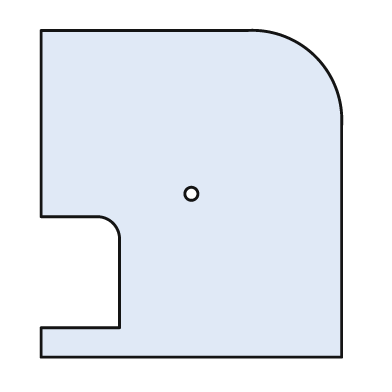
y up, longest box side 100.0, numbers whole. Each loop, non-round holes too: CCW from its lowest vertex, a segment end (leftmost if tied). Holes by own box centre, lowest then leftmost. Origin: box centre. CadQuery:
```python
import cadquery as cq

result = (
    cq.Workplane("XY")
    .moveTo(-46.0, -50.0)
    .lineTo(46.0, -50.0)
    .lineTo(46.0, 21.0)
    .threePointArc((38.0, 42.0), (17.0, 50.0))
    .lineTo(-46.0, 50.0)
    .lineTo(-46.0, -7.0)
    .lineTo(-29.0, -7.0)
    .threePointArc((-24.0, -9.0), (-22.0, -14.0))
    .lineTo(-22.0, -41.0)
    .lineTo(-46.0, -41.0)
    .close()
    .moveTo(0.0, 0.0)
    .circle(2.0)
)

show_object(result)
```